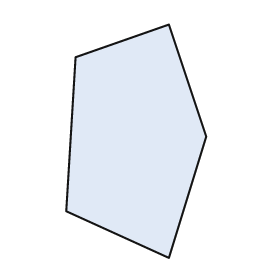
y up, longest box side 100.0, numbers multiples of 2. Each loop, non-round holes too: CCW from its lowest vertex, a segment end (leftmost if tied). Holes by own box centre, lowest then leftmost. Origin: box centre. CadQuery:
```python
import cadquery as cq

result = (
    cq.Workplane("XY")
    .moveTo(14.0, -50.0)
    .lineTo(30.0, 2.0)
    .lineTo(14.0, 50.0)
    .lineTo(-26.0, 36.0)
    .lineTo(-30.0, -30.0)
    .close()
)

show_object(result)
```